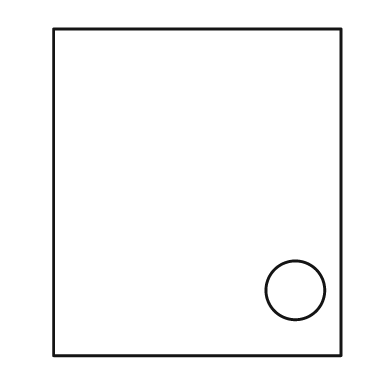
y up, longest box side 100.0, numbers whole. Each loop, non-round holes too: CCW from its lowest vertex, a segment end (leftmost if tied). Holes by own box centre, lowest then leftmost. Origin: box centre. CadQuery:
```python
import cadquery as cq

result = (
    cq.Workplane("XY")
    .moveTo(-44.0, -50.0)
    .lineTo(44.0, -50.0)
    .lineTo(44.0, 50.0)
    .lineTo(-44.0, 50.0)
    .close()
    .moveTo(30.0, -30.0)
    .circle(9.0)
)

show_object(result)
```